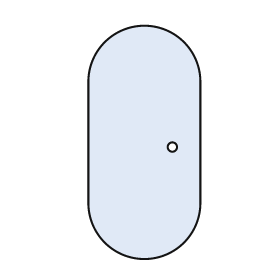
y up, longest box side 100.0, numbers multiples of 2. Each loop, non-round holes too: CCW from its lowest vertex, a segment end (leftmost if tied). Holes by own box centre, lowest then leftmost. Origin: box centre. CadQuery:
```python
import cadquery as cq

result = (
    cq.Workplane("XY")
    .moveTo(-24.0, -26.0)
    .threePointArc((0.0, -50.0), (24.0, -26.0))
    .lineTo(24.0, 26.0)
    .threePointArc((0.0, 50.0), (-24.0, 26.0))
    .close()
    .moveTo(12.0, -2.0)
    .circle(2.0)
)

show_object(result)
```